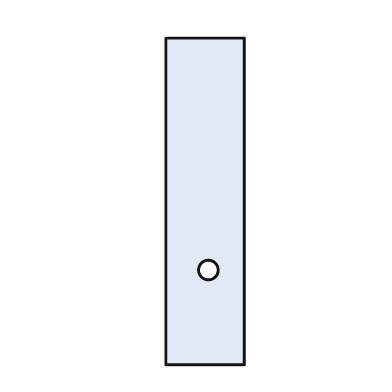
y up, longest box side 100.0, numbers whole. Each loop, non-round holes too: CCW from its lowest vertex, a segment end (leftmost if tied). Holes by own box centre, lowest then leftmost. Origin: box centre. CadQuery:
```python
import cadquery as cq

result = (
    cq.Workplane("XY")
    .moveTo(-12.0, -50.0)
    .lineTo(12.0, -50.0)
    .lineTo(12.0, 50.0)
    .lineTo(-12.0, 50.0)
    .close()
    .moveTo(1.0, -21.0)
    .circle(3.0)
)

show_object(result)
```